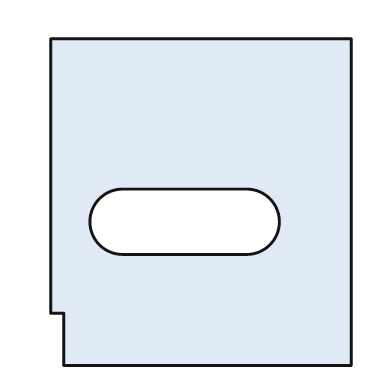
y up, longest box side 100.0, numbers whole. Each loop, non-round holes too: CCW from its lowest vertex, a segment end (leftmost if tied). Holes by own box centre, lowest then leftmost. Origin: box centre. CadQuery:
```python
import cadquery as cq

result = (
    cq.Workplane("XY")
    .moveTo(-42.0, -50.0)
    .lineTo(46.0, -50.0)
    .lineTo(46.0, 50.0)
    .lineTo(-46.0, 50.0)
    .lineTo(-46.0, -34.0)
    .lineTo(-42.0, -34.0)
    .close()
    .moveTo(-24.0, -16.0)
    .lineTo(14.0, -16.0)
    .threePointArc((24.0, -6.0), (14.0, 4.0))
    .lineTo(-24.0, 4.0)
    .threePointArc((-34.0, -6.0), (-24.0, -16.0))
    .close()
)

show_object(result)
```